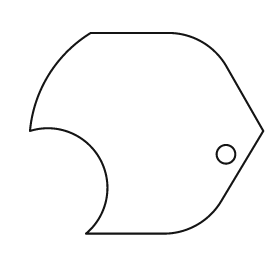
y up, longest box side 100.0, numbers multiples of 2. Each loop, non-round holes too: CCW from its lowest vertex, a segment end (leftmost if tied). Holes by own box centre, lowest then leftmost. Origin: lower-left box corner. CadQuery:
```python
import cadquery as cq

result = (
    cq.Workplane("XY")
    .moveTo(24.0, 0.0)
    .lineTo(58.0, 0.0)
    .threePointArc((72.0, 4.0), (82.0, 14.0))
    .lineTo(100.0, 44.0)
    .lineTo(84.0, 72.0)
    .threePointArc((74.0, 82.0), (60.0, 86.0))
    .lineTo(26.0, 86.0)
    .threePointArc((8.0, 68.0), (0.0, 44.0))
    .threePointArc((30.0, 32.0), (24.0, 0.0))
    .close()
    .moveTo(84.0, 34.0)
    .circle(4.0)
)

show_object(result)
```